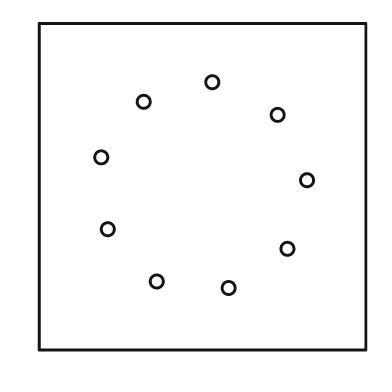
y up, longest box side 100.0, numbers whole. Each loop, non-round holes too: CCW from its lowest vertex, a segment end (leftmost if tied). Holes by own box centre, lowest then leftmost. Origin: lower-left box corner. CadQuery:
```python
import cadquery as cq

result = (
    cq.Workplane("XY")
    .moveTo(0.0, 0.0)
    .lineTo(100.0, 0.0)
    .lineTo(100.0, 100.0)
    .lineTo(0.0, 100.0)
    .close()
    .moveTo(58.0, 19.0)
    .circle(2.0)
    .moveTo(36.0, 21.0)
    .circle(2.0)
    .moveTo(76.0, 31.0)
    .circle(2.0)
    .moveTo(21.0, 37.0)
    .circle(2.0)
    .moveTo(82.0, 52.0)
    .circle(2.0)
    .moveTo(19.0, 59.0)
    .circle(2.0)
    .moveTo(73.0, 72.0)
    .circle(2.0)
    .moveTo(32.0, 76.0)
    .circle(2.0)
    .moveTo(53.0, 82.0)
    .circle(2.0)
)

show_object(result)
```